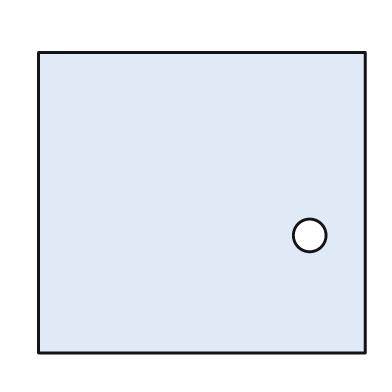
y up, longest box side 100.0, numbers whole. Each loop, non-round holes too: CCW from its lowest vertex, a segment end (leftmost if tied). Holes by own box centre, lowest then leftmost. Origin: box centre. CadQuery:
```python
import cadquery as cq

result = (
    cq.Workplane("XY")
    .moveTo(-50.0, -46.0)
    .lineTo(50.0, -46.0)
    .lineTo(50.0, 46.0)
    .lineTo(-50.0, 46.0)
    .close()
    .moveTo(33.0, -10.0)
    .circle(5.0)
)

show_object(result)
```